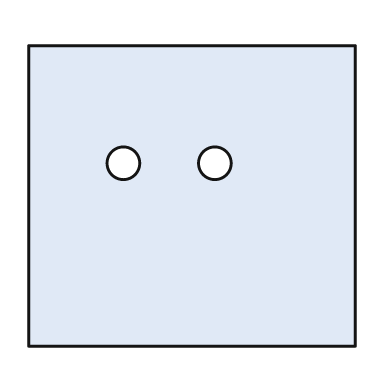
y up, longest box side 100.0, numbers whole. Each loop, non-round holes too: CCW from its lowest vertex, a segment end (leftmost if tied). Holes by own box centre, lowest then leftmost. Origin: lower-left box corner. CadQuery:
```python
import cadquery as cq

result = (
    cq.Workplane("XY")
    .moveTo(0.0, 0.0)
    .lineTo(100.0, 0.0)
    .lineTo(100.0, 92.0)
    .lineTo(0.0, 92.0)
    .close()
    .moveTo(29.0, 56.0)
    .circle(5.0)
    .moveTo(57.0, 56.0)
    .circle(5.0)
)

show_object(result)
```